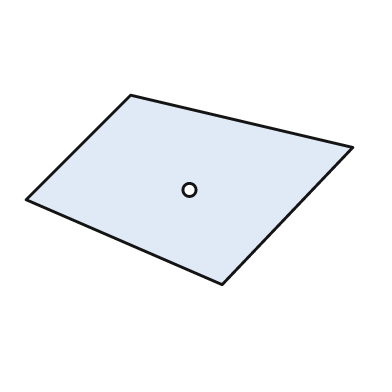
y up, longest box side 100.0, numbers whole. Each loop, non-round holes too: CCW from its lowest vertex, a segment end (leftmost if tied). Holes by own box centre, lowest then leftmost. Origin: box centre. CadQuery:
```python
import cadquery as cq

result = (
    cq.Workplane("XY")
    .moveTo(10.0, -29.0)
    .lineTo(50.0, 13.0)
    .lineTo(-18.0, 29.0)
    .lineTo(-50.0, -3.0)
    .close()
    .moveTo(0.0, 0.0)
    .circle(2.0)
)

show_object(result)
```